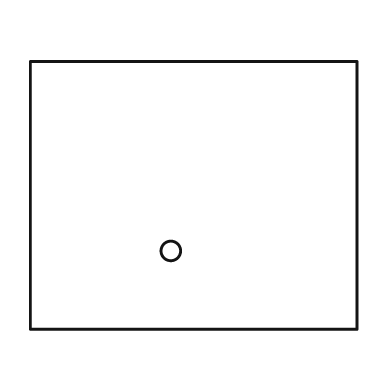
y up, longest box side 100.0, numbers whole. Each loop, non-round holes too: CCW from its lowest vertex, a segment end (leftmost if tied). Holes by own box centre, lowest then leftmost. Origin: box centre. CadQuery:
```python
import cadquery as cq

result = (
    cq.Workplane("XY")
    .moveTo(-50.0, -41.0)
    .lineTo(50.0, -41.0)
    .lineTo(50.0, 41.0)
    .lineTo(-50.0, 41.0)
    .close()
    .moveTo(-7.0, -17.0)
    .circle(3.0)
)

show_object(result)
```